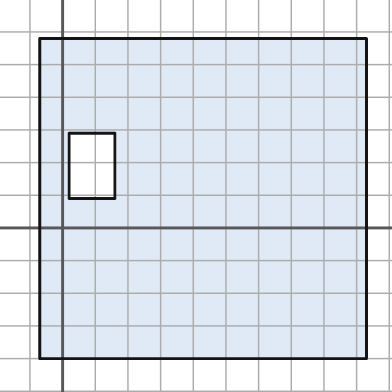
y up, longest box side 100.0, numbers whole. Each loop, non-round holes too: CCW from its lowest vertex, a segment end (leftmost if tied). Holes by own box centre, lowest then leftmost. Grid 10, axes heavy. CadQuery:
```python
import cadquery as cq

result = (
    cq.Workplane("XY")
    .moveTo(-7.0, -40.0)
    .lineTo(93.0, -40.0)
    .lineTo(93.0, 58.0)
    .lineTo(-7.0, 58.0)
    .close()
    .moveTo(2.0, 9.0)
    .lineTo(16.0, 9.0)
    .lineTo(16.0, 29.0)
    .lineTo(2.0, 29.0)
    .close()
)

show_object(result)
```